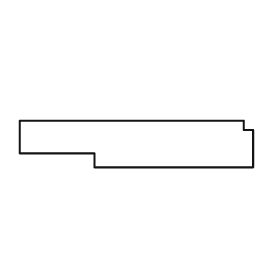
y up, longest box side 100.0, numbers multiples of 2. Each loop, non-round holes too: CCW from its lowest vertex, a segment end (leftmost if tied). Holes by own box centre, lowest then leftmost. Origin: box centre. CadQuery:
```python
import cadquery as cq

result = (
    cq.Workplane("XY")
    .moveTo(-18.0, -10.0)
    .lineTo(50.0, -10.0)
    .lineTo(50.0, 6.0)
    .lineTo(46.0, 6.0)
    .lineTo(46.0, 10.0)
    .lineTo(-50.0, 10.0)
    .lineTo(-50.0, -4.0)
    .lineTo(-18.0, -4.0)
    .close()
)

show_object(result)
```